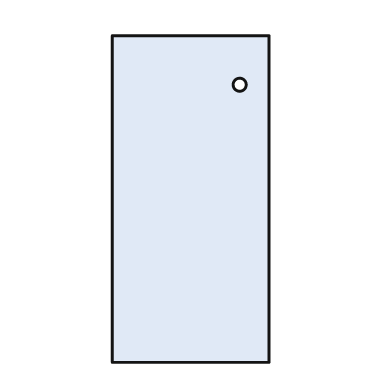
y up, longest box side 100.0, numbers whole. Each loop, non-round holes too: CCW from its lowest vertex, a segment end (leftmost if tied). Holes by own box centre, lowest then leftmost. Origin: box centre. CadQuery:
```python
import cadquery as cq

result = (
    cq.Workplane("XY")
    .moveTo(-24.0, -50.0)
    .lineTo(24.0, -50.0)
    .lineTo(24.0, 50.0)
    .lineTo(-24.0, 50.0)
    .close()
    .moveTo(15.0, 35.0)
    .circle(2.0)
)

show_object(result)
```